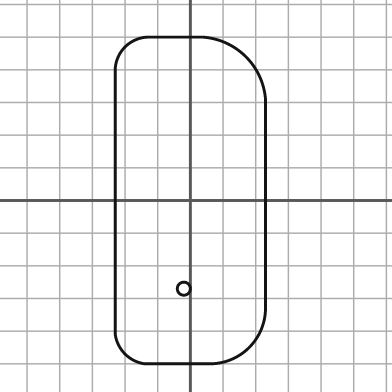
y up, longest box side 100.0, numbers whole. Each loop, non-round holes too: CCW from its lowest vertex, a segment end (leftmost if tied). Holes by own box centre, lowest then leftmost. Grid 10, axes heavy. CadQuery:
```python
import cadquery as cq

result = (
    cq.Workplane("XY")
    .moveTo(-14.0, -50.0)
    .lineTo(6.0, -50.0)
    .threePointArc((18.0, -45.0), (23.0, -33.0))
    .lineTo(23.0, 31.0)
    .threePointArc((17.0, 44.0), (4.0, 50.0))
    .lineTo(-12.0, 50.0)
    .threePointArc((-20.0, 47.0), (-23.0, 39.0))
    .lineTo(-23.0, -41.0)
    .threePointArc((-20.0, -47.0), (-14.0, -50.0))
    .close()
    .moveTo(-2.0, -27.0)
    .circle(2.0)
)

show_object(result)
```